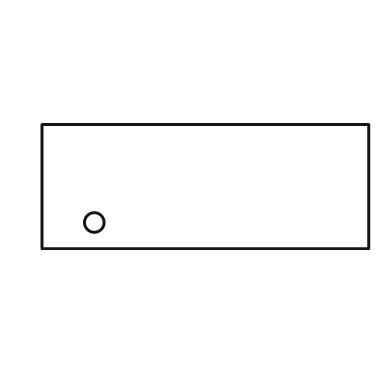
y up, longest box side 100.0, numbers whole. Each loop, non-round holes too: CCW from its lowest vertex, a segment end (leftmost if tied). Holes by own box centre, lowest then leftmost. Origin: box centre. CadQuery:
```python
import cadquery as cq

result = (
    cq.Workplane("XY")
    .moveTo(-50.0, -19.0)
    .lineTo(50.0, -19.0)
    .lineTo(50.0, 19.0)
    .lineTo(-50.0, 19.0)
    .close()
    .moveTo(-34.0, -11.0)
    .circle(3.0)
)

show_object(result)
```